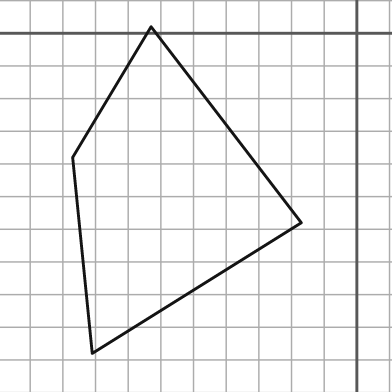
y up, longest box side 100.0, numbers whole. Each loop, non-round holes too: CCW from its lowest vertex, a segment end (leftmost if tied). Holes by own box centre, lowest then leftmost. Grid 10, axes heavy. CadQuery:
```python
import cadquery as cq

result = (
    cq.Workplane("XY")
    .moveTo(-81.0, -98.0)
    .lineTo(-17.0, -58.0)
    .lineTo(-63.0, 2.0)
    .lineTo(-87.0, -38.0)
    .close()
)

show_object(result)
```